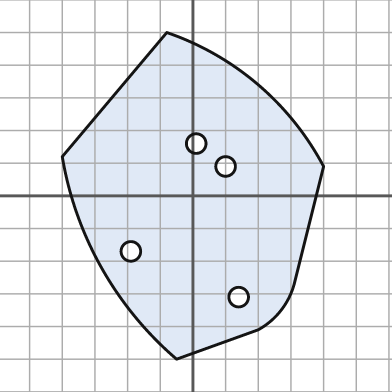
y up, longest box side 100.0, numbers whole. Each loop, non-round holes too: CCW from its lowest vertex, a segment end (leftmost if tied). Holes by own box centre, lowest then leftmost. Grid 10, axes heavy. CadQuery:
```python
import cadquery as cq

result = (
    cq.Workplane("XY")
    .moveTo(-5.0, -50.0)
    .lineTo(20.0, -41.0)
    .threePointArc((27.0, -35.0), (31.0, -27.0))
    .lineTo(40.0, 9.0)
    .threePointArc((20.0, 34.0), (-8.0, 50.0))
    .lineTo(-40.0, 12.0)
    .threePointArc((-28.0, -22.0), (-5.0, -50.0))
    .close()
    .moveTo(14.0, -31.0)
    .circle(3.0)
    .moveTo(-19.0, -17.0)
    .circle(3.0)
    .moveTo(10.0, 9.0)
    .circle(3.0)
    .moveTo(1.0, 16.0)
    .circle(3.0)
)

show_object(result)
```